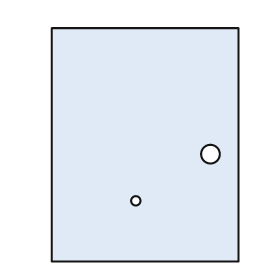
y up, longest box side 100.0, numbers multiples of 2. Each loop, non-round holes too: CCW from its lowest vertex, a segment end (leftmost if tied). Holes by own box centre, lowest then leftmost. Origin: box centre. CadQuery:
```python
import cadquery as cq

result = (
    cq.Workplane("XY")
    .moveTo(-40.0, -50.0)
    .lineTo(40.0, -50.0)
    .lineTo(40.0, 50.0)
    .lineTo(-40.0, 50.0)
    .close()
    .moveTo(-4.0, -24.0)
    .circle(2.0)
    .moveTo(28.0, -4.0)
    .circle(4.0)
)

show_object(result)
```